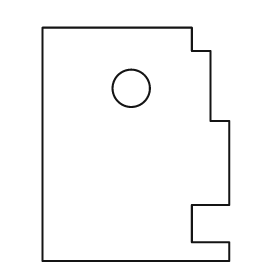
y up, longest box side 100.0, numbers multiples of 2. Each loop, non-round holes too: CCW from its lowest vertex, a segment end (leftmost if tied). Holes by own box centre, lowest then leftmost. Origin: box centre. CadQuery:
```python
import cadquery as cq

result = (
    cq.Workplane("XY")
    .moveTo(-40.0, -50.0)
    .lineTo(40.0, -50.0)
    .lineTo(40.0, -42.0)
    .lineTo(24.0, -42.0)
    .lineTo(24.0, -26.0)
    .lineTo(40.0, -26.0)
    .lineTo(40.0, 10.0)
    .lineTo(32.0, 10.0)
    .lineTo(32.0, 40.0)
    .lineTo(24.0, 40.0)
    .lineTo(24.0, 50.0)
    .lineTo(-40.0, 50.0)
    .close()
    .moveTo(-2.0, 24.0)
    .circle(8.0)
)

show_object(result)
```